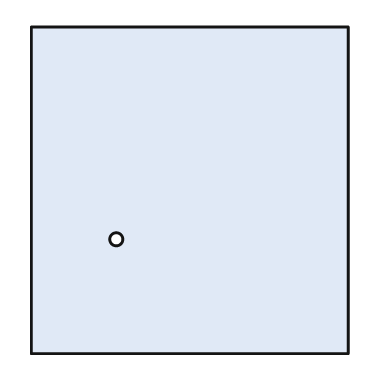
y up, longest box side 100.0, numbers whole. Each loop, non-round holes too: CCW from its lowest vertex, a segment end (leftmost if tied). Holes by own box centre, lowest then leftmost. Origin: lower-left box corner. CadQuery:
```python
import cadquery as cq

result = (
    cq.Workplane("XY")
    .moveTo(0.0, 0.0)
    .lineTo(97.0, 0.0)
    .lineTo(97.0, 100.0)
    .lineTo(0.0, 100.0)
    .close()
    .moveTo(26.0, 35.0)
    .circle(2.0)
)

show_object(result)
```